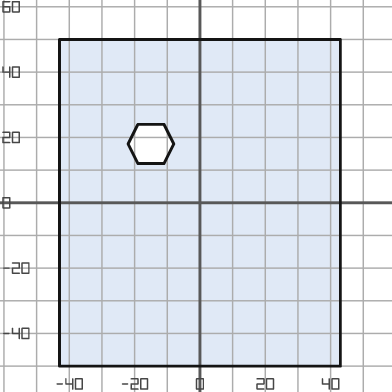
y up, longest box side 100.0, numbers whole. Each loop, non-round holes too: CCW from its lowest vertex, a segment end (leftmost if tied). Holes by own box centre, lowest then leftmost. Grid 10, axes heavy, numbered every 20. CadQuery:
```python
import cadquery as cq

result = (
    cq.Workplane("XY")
    .moveTo(-43.0, -50.0)
    .lineTo(43.0, -50.0)
    .lineTo(43.0, 50.0)
    .lineTo(-43.0, 50.0)
    .close()
    .moveTo(-19.0, 12.0)
    .lineTo(-11.0, 12.0)
    .lineTo(-8.0, 18.0)
    .lineTo(-11.0, 24.0)
    .lineTo(-19.0, 24.0)
    .lineTo(-22.0, 18.0)
    .close()
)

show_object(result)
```